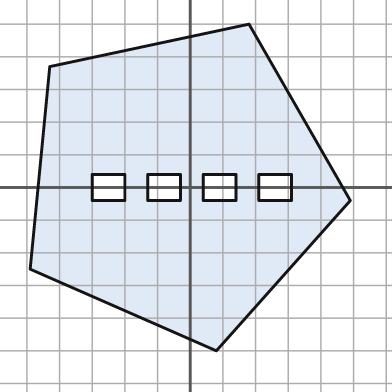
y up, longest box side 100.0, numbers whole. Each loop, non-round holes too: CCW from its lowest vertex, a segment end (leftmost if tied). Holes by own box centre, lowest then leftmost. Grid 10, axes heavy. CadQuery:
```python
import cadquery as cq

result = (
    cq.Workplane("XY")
    .moveTo(8.0, -50.0)
    .lineTo(49.0, -4.0)
    .lineTo(18.0, 50.0)
    .lineTo(-43.0, 37.0)
    .lineTo(-49.0, -25.0)
    .close()
    .moveTo(-30.0, -4.0)
    .lineTo(-20.0, -4.0)
    .lineTo(-20.0, 4.0)
    .lineTo(-30.0, 4.0)
    .close()
    .moveTo(-13.0, -4.0)
    .lineTo(-3.0, -4.0)
    .lineTo(-3.0, 4.0)
    .lineTo(-13.0, 4.0)
    .close()
    .moveTo(4.0, -4.0)
    .lineTo(14.0, -4.0)
    .lineTo(14.0, 4.0)
    .lineTo(4.0, 4.0)
    .close()
    .moveTo(21.0, -4.0)
    .lineTo(31.0, -4.0)
    .lineTo(31.0, 4.0)
    .lineTo(21.0, 4.0)
    .close()
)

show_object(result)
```